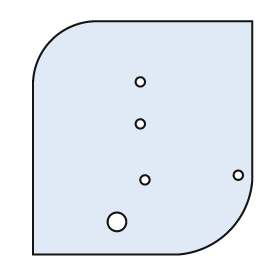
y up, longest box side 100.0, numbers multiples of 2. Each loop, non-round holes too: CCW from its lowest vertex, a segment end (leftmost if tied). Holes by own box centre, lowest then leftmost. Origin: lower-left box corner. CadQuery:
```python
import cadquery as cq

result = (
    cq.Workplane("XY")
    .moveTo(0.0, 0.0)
    .lineTo(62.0, 0.0)
    .threePointArc((84.0, 10.0), (94.0, 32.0))
    .lineTo(94.0, 100.0)
    .lineTo(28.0, 100.0)
    .threePointArc((8.0, 92.0), (0.0, 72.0))
    .close()
    .moveTo(36.0, 14.0)
    .circle(4.0)
    .moveTo(48.0, 32.0)
    .circle(2.0)
    .moveTo(88.0, 34.0)
    .circle(2.0)
    .moveTo(46.0, 56.0)
    .circle(2.0)
    .moveTo(46.0, 74.0)
    .circle(2.0)
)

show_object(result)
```